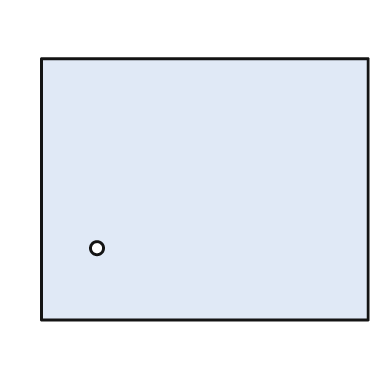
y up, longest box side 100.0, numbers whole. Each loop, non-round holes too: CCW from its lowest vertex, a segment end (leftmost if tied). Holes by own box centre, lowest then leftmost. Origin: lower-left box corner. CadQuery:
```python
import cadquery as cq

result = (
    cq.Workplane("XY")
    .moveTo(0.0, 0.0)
    .lineTo(100.0, 0.0)
    .lineTo(100.0, 80.0)
    .lineTo(0.0, 80.0)
    .close()
    .moveTo(17.0, 22.0)
    .circle(2.0)
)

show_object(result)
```